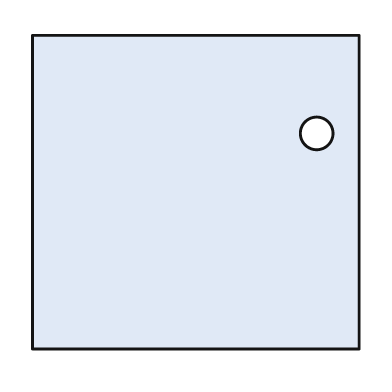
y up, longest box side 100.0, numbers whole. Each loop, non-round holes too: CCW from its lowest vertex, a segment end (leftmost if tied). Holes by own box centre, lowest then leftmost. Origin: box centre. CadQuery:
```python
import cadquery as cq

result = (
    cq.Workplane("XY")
    .moveTo(-50.0, -48.0)
    .lineTo(50.0, -48.0)
    .lineTo(50.0, 48.0)
    .lineTo(-50.0, 48.0)
    .close()
    .moveTo(37.0, 18.0)
    .circle(5.0)
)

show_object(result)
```